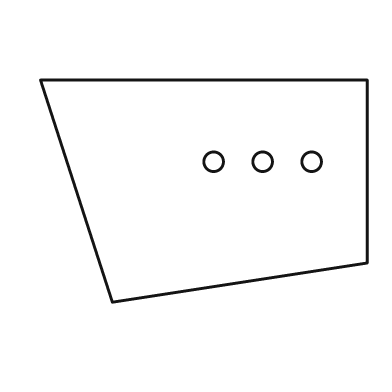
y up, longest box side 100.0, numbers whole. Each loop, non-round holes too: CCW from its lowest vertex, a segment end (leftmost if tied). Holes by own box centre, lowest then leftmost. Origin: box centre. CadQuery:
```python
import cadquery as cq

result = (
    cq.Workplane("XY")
    .moveTo(-28.0, -34.0)
    .lineTo(50.0, -22.0)
    .lineTo(50.0, 34.0)
    .lineTo(-50.0, 34.0)
    .close()
    .moveTo(3.0, 9.0)
    .circle(3.0)
    .moveTo(18.0, 9.0)
    .circle(3.0)
    .moveTo(33.0, 9.0)
    .circle(3.0)
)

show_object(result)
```